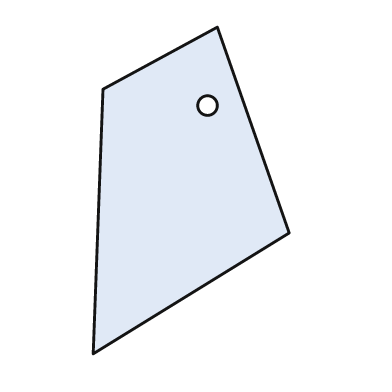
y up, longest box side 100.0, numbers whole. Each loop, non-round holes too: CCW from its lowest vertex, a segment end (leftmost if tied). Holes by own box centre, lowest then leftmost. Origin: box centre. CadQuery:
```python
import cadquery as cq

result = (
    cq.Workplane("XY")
    .moveTo(-30.0, -50.0)
    .lineTo(30.0, -13.0)
    .lineTo(8.0, 50.0)
    .lineTo(-27.0, 31.0)
    .close()
    .moveTo(5.0, 26.0)
    .circle(3.0)
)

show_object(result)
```